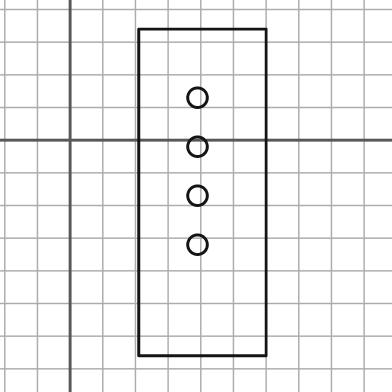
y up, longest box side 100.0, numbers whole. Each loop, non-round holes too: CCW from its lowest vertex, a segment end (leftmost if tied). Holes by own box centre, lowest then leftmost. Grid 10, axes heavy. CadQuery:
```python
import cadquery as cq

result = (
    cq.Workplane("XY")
    .moveTo(21.0, -66.0)
    .lineTo(60.0, -66.0)
    .lineTo(60.0, 34.0)
    .lineTo(21.0, 34.0)
    .close()
    .moveTo(39.0, -32.0)
    .circle(3.0)
    .moveTo(39.0, -17.0)
    .circle(3.0)
    .moveTo(39.0, -2.0)
    .circle(3.0)
    .moveTo(39.0, 13.0)
    .circle(3.0)
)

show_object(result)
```